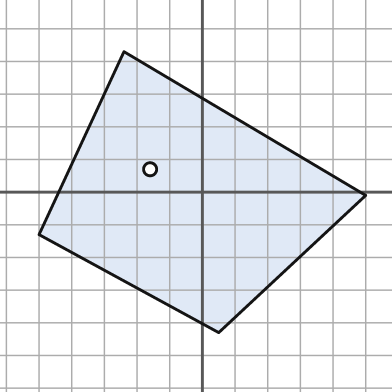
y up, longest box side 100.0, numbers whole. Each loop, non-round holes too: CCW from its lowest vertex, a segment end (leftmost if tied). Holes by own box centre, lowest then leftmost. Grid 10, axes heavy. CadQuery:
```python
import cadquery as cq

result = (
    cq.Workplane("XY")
    .moveTo(5.0, -43.0)
    .lineTo(50.0, -1.0)
    .lineTo(-24.0, 43.0)
    .lineTo(-50.0, -13.0)
    .close()
    .moveTo(-16.0, 7.0)
    .circle(2.0)
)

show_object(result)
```